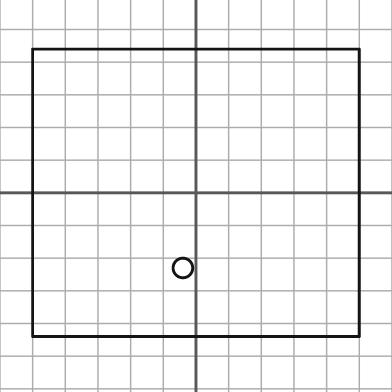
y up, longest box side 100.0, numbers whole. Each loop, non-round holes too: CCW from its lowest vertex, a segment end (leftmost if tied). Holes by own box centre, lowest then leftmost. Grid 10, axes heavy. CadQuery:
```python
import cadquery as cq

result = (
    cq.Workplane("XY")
    .moveTo(-50.0, -44.0)
    .lineTo(50.0, -44.0)
    .lineTo(50.0, 44.0)
    .lineTo(-50.0, 44.0)
    .close()
    .moveTo(-4.0, -23.0)
    .circle(3.0)
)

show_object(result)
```